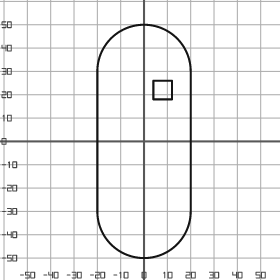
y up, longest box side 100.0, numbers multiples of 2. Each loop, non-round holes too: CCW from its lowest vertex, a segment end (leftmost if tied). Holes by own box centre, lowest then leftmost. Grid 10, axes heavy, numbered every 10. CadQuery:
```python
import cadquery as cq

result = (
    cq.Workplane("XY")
    .moveTo(-20.0, -30.0)
    .threePointArc((0.0, -50.0), (20.0, -30.0))
    .lineTo(20.0, 30.0)
    .threePointArc((0.0, 50.0), (-20.0, 30.0))
    .close()
    .moveTo(4.0, 18.0)
    .lineTo(12.0, 18.0)
    .lineTo(12.0, 26.0)
    .lineTo(4.0, 26.0)
    .close()
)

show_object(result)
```